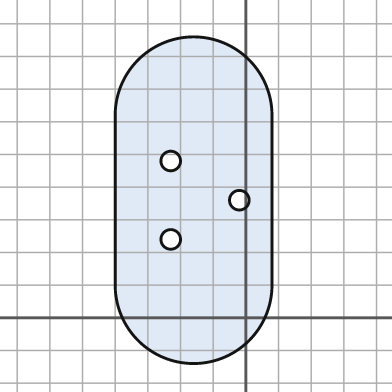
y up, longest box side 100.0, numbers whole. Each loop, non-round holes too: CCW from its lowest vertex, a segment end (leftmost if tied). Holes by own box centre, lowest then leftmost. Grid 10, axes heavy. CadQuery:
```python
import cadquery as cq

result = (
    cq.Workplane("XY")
    .moveTo(-40.0, 10.0)
    .threePointArc((-16.0, -14.0), (8.0, 10.0))
    .lineTo(8.0, 62.0)
    .threePointArc((-16.0, 86.0), (-40.0, 62.0))
    .close()
    .moveTo(-23.0, 24.0)
    .circle(3.0)
    .moveTo(-2.0, 36.0)
    .circle(3.0)
    .moveTo(-23.0, 48.0)
    .circle(3.0)
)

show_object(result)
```